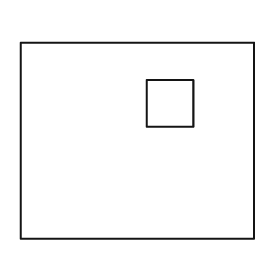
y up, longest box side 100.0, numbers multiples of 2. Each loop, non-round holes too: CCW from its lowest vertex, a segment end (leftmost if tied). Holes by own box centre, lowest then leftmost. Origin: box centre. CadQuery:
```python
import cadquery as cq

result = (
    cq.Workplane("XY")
    .moveTo(-50.0, -42.0)
    .lineTo(50.0, -42.0)
    .lineTo(50.0, 42.0)
    .lineTo(-50.0, 42.0)
    .close()
    .moveTo(4.0, 6.0)
    .lineTo(24.0, 6.0)
    .lineTo(24.0, 26.0)
    .lineTo(4.0, 26.0)
    .close()
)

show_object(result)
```